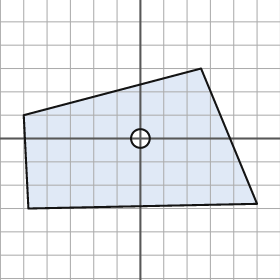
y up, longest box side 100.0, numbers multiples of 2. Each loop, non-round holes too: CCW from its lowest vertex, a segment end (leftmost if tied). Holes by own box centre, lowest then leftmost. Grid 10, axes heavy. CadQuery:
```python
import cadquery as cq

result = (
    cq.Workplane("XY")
    .moveTo(-48.0, -30.0)
    .lineTo(50.0, -28.0)
    .lineTo(26.0, 30.0)
    .lineTo(-50.0, 10.0)
    .close()
    .moveTo(0.0, 0.0)
    .circle(4.0)
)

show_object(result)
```